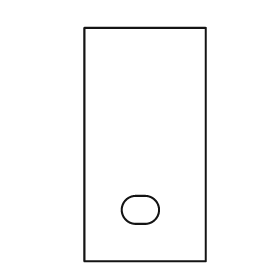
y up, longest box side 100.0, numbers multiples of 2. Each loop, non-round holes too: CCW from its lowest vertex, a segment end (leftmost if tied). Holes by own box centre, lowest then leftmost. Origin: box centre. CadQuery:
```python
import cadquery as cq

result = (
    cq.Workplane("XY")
    .moveTo(-26.0, -50.0)
    .lineTo(26.0, -50.0)
    .lineTo(26.0, 50.0)
    .lineTo(-26.0, 50.0)
    .close()
    .moveTo(-4.0, -34.0)
    .lineTo(0.0, -34.0)
    .threePointArc((6.0, -28.0), (0.0, -22.0))
    .lineTo(-4.0, -22.0)
    .threePointArc((-10.0, -28.0), (-4.0, -34.0))
    .close()
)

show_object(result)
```